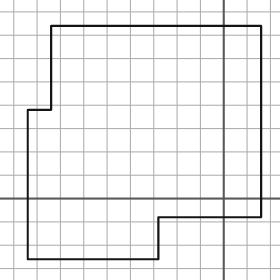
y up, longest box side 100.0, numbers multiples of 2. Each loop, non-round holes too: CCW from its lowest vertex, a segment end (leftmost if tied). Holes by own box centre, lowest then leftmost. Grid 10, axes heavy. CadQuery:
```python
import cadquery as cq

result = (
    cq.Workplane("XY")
    .moveTo(-84.0, -26.0)
    .lineTo(-28.0, -26.0)
    .lineTo(-28.0, -8.0)
    .lineTo(16.0, -8.0)
    .lineTo(16.0, 74.0)
    .lineTo(-74.0, 74.0)
    .lineTo(-74.0, 38.0)
    .lineTo(-84.0, 38.0)
    .close()
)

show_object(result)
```